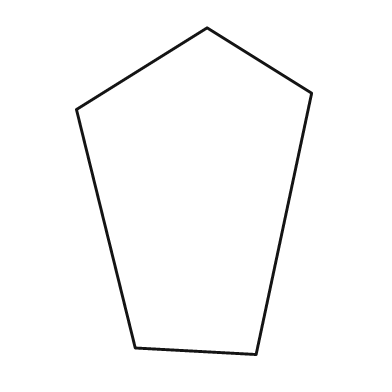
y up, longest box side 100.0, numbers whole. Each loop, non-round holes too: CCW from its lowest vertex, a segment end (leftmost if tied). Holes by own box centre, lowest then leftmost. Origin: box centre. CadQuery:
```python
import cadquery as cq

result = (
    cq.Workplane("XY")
    .moveTo(19.0, -50.0)
    .lineTo(36.0, 30.0)
    .lineTo(4.0, 50.0)
    .lineTo(-36.0, 25.0)
    .lineTo(-18.0, -48.0)
    .close()
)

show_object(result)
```